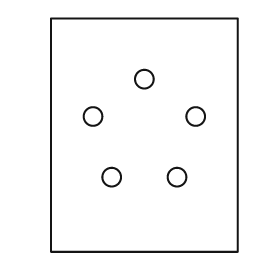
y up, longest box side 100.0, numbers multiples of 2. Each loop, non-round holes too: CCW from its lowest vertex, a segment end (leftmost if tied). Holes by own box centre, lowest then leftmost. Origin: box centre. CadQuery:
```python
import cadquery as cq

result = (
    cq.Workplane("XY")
    .moveTo(-40.0, -50.0)
    .lineTo(40.0, -50.0)
    .lineTo(40.0, 50.0)
    .lineTo(-40.0, 50.0)
    .close()
    .moveTo(-14.0, -18.0)
    .circle(4.0)
    .moveTo(14.0, -18.0)
    .circle(4.0)
    .moveTo(-22.0, 8.0)
    .circle(4.0)
    .moveTo(22.0, 8.0)
    .circle(4.0)
    .moveTo(0.0, 24.0)
    .circle(4.0)
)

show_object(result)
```